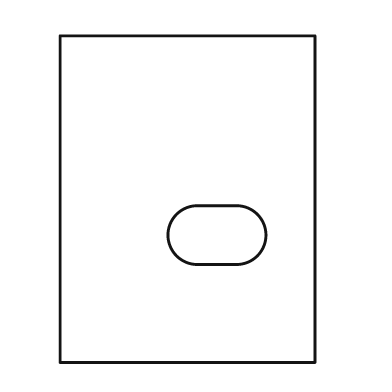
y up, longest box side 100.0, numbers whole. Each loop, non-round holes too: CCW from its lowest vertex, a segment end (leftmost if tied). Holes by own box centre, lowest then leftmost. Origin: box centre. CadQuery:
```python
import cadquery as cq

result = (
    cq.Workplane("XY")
    .moveTo(-39.0, -50.0)
    .lineTo(39.0, -50.0)
    .lineTo(39.0, 50.0)
    .lineTo(-39.0, 50.0)
    .close()
    .moveTo(3.0, -20.0)
    .lineTo(15.0, -20.0)
    .threePointArc((24.0, -11.0), (15.0, -2.0))
    .lineTo(3.0, -2.0)
    .threePointArc((-6.0, -11.0), (3.0, -20.0))
    .close()
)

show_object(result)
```